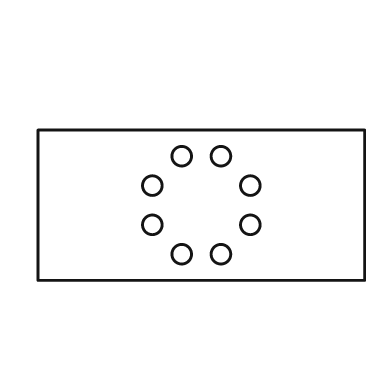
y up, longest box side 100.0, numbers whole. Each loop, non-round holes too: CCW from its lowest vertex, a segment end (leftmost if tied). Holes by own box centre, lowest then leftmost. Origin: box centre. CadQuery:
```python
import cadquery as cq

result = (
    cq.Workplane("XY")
    .moveTo(-50.0, -23.0)
    .lineTo(50.0, -23.0)
    .lineTo(50.0, 23.0)
    .lineTo(-50.0, 23.0)
    .close()
    .moveTo(-6.0, -15.0)
    .circle(3.0)
    .moveTo(6.0, -15.0)
    .circle(3.0)
    .moveTo(-15.0, -6.0)
    .circle(3.0)
    .moveTo(15.0, -6.0)
    .circle(3.0)
    .moveTo(-15.0, 6.0)
    .circle(3.0)
    .moveTo(15.0, 6.0)
    .circle(3.0)
    .moveTo(-6.0, 15.0)
    .circle(3.0)
    .moveTo(6.0, 15.0)
    .circle(3.0)
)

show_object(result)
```